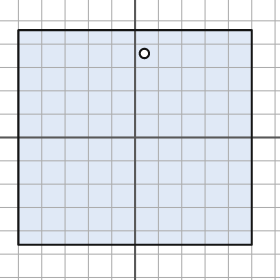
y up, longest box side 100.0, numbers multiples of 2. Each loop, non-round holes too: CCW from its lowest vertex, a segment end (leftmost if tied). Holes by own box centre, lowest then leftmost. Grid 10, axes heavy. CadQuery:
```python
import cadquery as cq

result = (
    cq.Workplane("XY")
    .moveTo(-50.0, -46.0)
    .lineTo(50.0, -46.0)
    .lineTo(50.0, 46.0)
    .lineTo(-50.0, 46.0)
    .close()
    .moveTo(4.0, 36.0)
    .circle(2.0)
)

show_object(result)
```